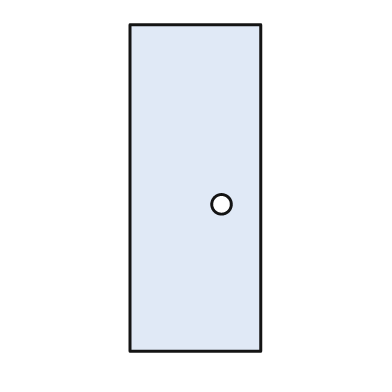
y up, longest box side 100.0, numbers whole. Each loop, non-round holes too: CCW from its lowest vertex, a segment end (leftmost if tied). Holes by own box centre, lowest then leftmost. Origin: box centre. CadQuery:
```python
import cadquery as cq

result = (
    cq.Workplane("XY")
    .moveTo(-20.0, -50.0)
    .lineTo(20.0, -50.0)
    .lineTo(20.0, 50.0)
    .lineTo(-20.0, 50.0)
    .close()
    .moveTo(8.0, -5.0)
    .circle(3.0)
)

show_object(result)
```